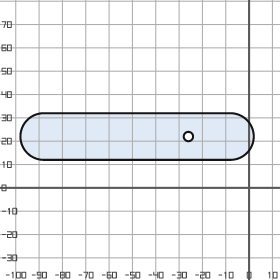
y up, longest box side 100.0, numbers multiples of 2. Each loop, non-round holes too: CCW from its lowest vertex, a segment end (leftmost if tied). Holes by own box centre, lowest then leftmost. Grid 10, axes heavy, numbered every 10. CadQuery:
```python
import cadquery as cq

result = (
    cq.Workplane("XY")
    .moveTo(-88.0, 12.0)
    .lineTo(-8.0, 12.0)
    .threePointArc((2.0, 22.0), (-8.0, 32.0))
    .lineTo(-88.0, 32.0)
    .threePointArc((-98.0, 22.0), (-88.0, 12.0))
    .close()
    .moveTo(-26.0, 22.0)
    .circle(2.0)
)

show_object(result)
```